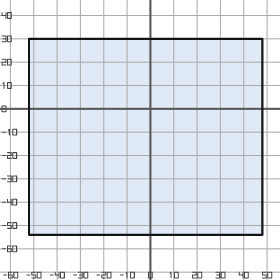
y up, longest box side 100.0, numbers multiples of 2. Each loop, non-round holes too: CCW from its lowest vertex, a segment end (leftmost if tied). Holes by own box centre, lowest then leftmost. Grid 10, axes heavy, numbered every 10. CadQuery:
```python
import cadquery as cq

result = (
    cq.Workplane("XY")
    .moveTo(-52.0, -54.0)
    .lineTo(48.0, -54.0)
    .lineTo(48.0, 30.0)
    .lineTo(-52.0, 30.0)
    .close()
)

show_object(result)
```